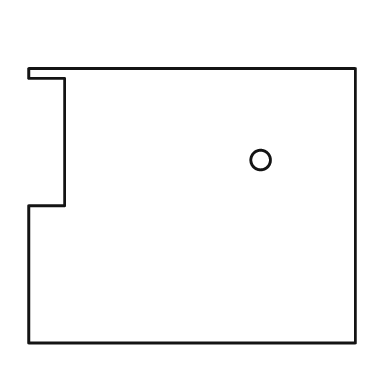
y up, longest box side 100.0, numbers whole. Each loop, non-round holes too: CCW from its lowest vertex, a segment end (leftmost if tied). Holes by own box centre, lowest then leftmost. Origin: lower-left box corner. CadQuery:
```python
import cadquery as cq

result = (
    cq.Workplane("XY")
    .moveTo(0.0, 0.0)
    .lineTo(100.0, 0.0)
    .lineTo(100.0, 84.0)
    .lineTo(0.0, 84.0)
    .lineTo(0.0, 81.0)
    .lineTo(11.0, 81.0)
    .lineTo(11.0, 42.0)
    .lineTo(0.0, 42.0)
    .close()
    .moveTo(71.0, 56.0)
    .circle(3.0)
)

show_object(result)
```